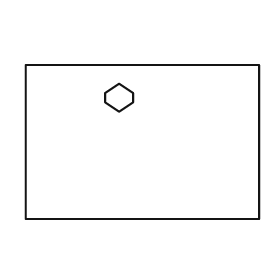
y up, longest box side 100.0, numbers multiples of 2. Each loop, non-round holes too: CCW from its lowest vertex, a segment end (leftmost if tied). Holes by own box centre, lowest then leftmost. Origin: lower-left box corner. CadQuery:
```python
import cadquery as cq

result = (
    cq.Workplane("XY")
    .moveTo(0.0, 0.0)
    .lineTo(100.0, 0.0)
    .lineTo(100.0, 66.0)
    .lineTo(0.0, 66.0)
    .close()
    .moveTo(40.0, 46.0)
    .lineTo(46.0, 50.0)
    .lineTo(46.0, 54.0)
    .lineTo(40.0, 58.0)
    .lineTo(34.0, 54.0)
    .lineTo(34.0, 50.0)
    .close()
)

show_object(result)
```